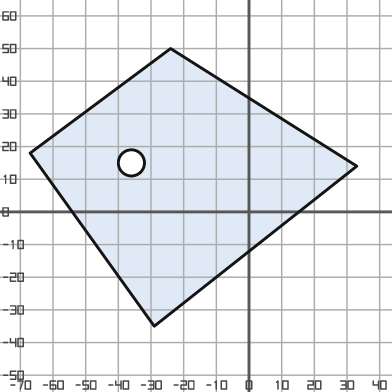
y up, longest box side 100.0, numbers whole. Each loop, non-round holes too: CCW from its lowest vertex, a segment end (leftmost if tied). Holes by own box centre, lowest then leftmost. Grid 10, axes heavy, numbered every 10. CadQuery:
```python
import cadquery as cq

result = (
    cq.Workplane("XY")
    .moveTo(-29.0, -35.0)
    .lineTo(33.0, 14.0)
    .lineTo(-24.0, 50.0)
    .lineTo(-67.0, 18.0)
    .close()
    .moveTo(-36.0, 15.0)
    .circle(4.0)
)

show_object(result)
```